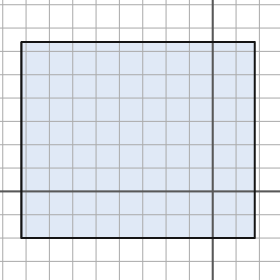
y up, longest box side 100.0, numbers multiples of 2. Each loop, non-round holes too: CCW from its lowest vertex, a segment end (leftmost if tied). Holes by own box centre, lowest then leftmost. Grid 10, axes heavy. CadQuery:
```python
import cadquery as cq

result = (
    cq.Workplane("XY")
    .moveTo(-82.0, -20.0)
    .lineTo(18.0, -20.0)
    .lineTo(18.0, 64.0)
    .lineTo(-82.0, 64.0)
    .close()
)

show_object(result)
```